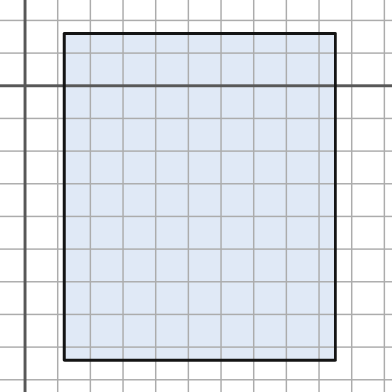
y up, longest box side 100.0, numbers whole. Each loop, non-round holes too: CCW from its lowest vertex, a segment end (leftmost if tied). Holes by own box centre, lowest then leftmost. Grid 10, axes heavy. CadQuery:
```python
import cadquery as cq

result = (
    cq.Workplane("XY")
    .moveTo(12.0, -84.0)
    .lineTo(95.0, -84.0)
    .lineTo(95.0, 16.0)
    .lineTo(12.0, 16.0)
    .close()
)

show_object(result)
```